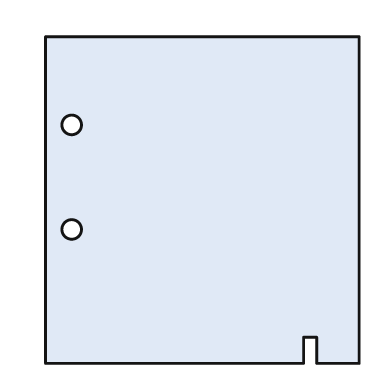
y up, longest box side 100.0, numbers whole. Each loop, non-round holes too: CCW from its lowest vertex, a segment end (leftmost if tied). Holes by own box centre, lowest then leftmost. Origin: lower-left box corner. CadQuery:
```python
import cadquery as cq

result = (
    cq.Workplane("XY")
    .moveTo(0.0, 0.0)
    .lineTo(79.0, 0.0)
    .lineTo(79.0, 8.0)
    .lineTo(83.0, 8.0)
    .lineTo(83.0, 0.0)
    .lineTo(96.0, 0.0)
    .lineTo(96.0, 100.0)
    .lineTo(0.0, 100.0)
    .close()
    .moveTo(8.0, 41.0)
    .circle(3.0)
    .moveTo(8.0, 73.0)
    .circle(3.0)
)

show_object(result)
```